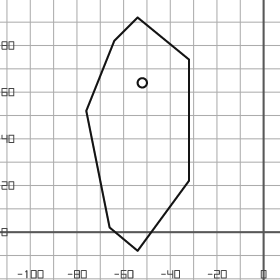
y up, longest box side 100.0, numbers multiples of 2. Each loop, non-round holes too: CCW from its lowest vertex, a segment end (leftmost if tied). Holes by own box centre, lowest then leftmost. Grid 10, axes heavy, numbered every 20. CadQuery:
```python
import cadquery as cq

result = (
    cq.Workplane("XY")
    .moveTo(-54.0, -8.0)
    .lineTo(-32.0, 22.0)
    .lineTo(-32.0, 74.0)
    .lineTo(-54.0, 92.0)
    .lineTo(-64.0, 82.0)
    .lineTo(-76.0, 52.0)
    .lineTo(-66.0, 2.0)
    .close()
    .moveTo(-52.0, 64.0)
    .circle(2.0)
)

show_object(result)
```